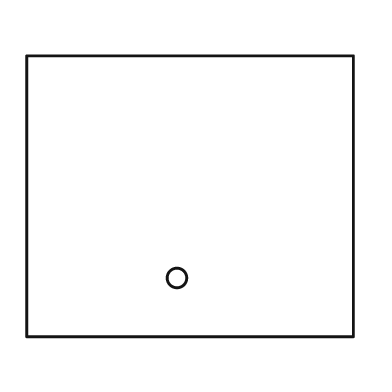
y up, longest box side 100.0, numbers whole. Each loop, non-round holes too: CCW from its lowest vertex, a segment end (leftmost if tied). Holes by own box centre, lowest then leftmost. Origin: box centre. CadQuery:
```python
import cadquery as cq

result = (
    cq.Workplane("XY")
    .moveTo(-50.0, -43.0)
    .lineTo(50.0, -43.0)
    .lineTo(50.0, 43.0)
    .lineTo(-50.0, 43.0)
    .close()
    .moveTo(-4.0, -25.0)
    .circle(3.0)
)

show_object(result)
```